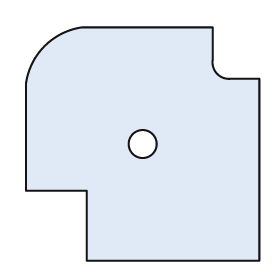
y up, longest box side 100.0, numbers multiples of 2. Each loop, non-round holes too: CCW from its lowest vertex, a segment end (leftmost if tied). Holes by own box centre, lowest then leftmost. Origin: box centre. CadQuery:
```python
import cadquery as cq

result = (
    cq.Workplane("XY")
    .moveTo(-24.0, -50.0)
    .lineTo(50.0, -50.0)
    .lineTo(50.0, 28.0)
    .lineTo(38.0, 28.0)
    .threePointArc((32.0, 30.0), (30.0, 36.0))
    .lineTo(30.0, 50.0)
    .lineTo(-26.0, 50.0)
    .threePointArc((-42.0, 42.0), (-50.0, 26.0))
    .lineTo(-50.0, -20.0)
    .lineTo(-24.0, -20.0)
    .close()
    .moveTo(0.0, 0.0)
    .circle(6.0)
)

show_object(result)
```